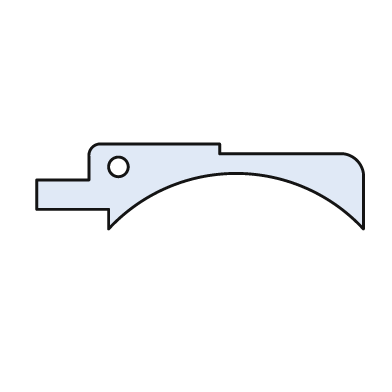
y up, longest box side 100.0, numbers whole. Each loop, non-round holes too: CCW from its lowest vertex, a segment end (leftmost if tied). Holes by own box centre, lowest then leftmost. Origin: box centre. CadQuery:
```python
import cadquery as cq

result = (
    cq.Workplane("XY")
    .moveTo(-28.0, -13.0)
    .threePointArc((11.0, 4.0), (50.0, -13.0))
    .lineTo(50.0, 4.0)
    .threePointArc((48.0, 8.0), (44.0, 10.0))
    .lineTo(6.0, 10.0)
    .lineTo(6.0, 13.0)
    .lineTo(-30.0, 13.0)
    .threePointArc((-33.0, 12.0), (-34.0, 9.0))
    .lineTo(-34.0, 2.0)
    .lineTo(-50.0, 2.0)
    .lineTo(-50.0, -7.0)
    .lineTo(-28.0, -7.0)
    .close()
    .moveTo(-25.0, 6.0)
    .circle(3.0)
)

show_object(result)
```